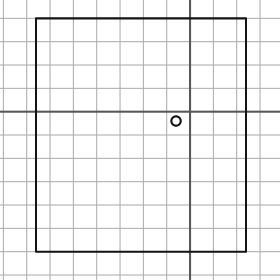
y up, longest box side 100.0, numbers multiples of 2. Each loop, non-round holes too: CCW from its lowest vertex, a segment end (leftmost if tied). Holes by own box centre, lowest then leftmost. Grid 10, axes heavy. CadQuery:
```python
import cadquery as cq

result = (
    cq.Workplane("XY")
    .moveTo(-66.0, -60.0)
    .lineTo(24.0, -60.0)
    .lineTo(24.0, 40.0)
    .lineTo(-66.0, 40.0)
    .close()
    .moveTo(-6.0, -4.0)
    .circle(2.0)
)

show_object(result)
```